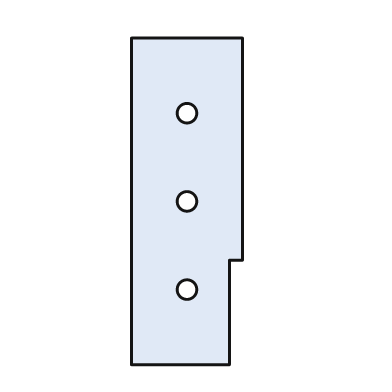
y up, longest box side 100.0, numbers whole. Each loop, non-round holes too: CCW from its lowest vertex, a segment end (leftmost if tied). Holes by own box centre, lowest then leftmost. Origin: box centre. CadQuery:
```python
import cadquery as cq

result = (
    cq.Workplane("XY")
    .moveTo(-17.0, -50.0)
    .lineTo(13.0, -50.0)
    .lineTo(13.0, -18.0)
    .lineTo(17.0, -18.0)
    .lineTo(17.0, 50.0)
    .lineTo(-17.0, 50.0)
    .close()
    .moveTo(0.0, -27.0)
    .circle(3.0)
    .moveTo(0.0, 0.0)
    .circle(3.0)
    .moveTo(0.0, 27.0)
    .circle(3.0)
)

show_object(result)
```